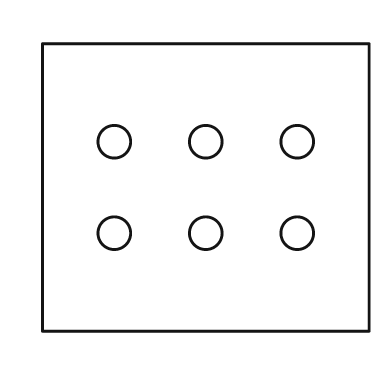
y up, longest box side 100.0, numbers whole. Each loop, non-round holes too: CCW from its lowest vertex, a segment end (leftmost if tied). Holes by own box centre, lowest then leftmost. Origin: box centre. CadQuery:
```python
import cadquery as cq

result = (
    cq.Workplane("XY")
    .moveTo(-50.0, -44.0)
    .lineTo(50.0, -44.0)
    .lineTo(50.0, 44.0)
    .lineTo(-50.0, 44.0)
    .close()
    .moveTo(-28.0, -14.0)
    .circle(5.0)
    .moveTo(0.0, -14.0)
    .circle(5.0)
    .moveTo(28.0, -14.0)
    .circle(5.0)
    .moveTo(-28.0, 14.0)
    .circle(5.0)
    .moveTo(0.0, 14.0)
    .circle(5.0)
    .moveTo(28.0, 14.0)
    .circle(5.0)
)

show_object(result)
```